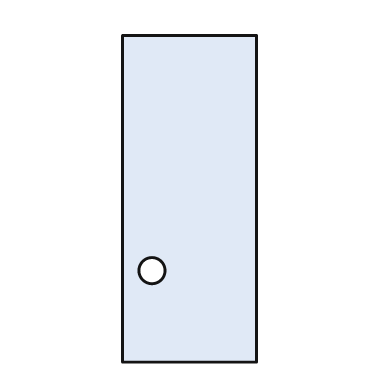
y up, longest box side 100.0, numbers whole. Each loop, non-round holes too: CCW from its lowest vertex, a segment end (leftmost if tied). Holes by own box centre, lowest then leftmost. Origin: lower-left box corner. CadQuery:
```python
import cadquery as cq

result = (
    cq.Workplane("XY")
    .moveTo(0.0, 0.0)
    .lineTo(41.0, 0.0)
    .lineTo(41.0, 100.0)
    .lineTo(0.0, 100.0)
    .close()
    .moveTo(9.0, 28.0)
    .circle(4.0)
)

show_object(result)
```